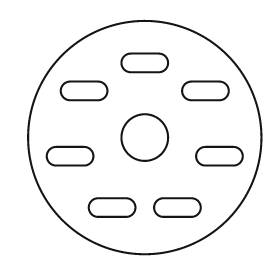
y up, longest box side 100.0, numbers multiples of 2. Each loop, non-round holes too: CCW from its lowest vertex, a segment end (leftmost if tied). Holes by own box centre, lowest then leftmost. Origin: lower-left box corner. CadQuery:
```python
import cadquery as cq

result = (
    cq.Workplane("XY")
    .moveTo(50.0, 50.0)
    .circle(50.0)
    .moveTo(30.0, 16.0)
    .lineTo(42.0, 16.0)
    .threePointArc((46.0, 20.0), (42.0, 24.0))
    .lineTo(30.0, 24.0)
    .threePointArc((26.0, 20.0), (30.0, 16.0))
    .close()
    .moveTo(58.0, 16.0)
    .lineTo(70.0, 16.0)
    .threePointArc((74.0, 20.0), (70.0, 24.0))
    .lineTo(58.0, 24.0)
    .threePointArc((54.0, 20.0), (58.0, 16.0))
    .close()
    .moveTo(12.0, 38.0)
    .lineTo(24.0, 38.0)
    .threePointArc((28.0, 42.0), (24.0, 46.0))
    .lineTo(12.0, 46.0)
    .threePointArc((8.0, 42.0), (12.0, 38.0))
    .close()
    .moveTo(76.0, 38.0)
    .lineTo(88.0, 38.0)
    .threePointArc((92.0, 42.0), (88.0, 46.0))
    .lineTo(76.0, 46.0)
    .threePointArc((72.0, 42.0), (76.0, 38.0))
    .close()
    .moveTo(50.0, 50.0)
    .circle(10.0)
    .moveTo(18.0, 66.0)
    .lineTo(30.0, 66.0)
    .threePointArc((34.0, 70.0), (30.0, 74.0))
    .lineTo(18.0, 74.0)
    .threePointArc((14.0, 70.0), (18.0, 66.0))
    .close()
    .moveTo(70.0, 66.0)
    .lineTo(82.0, 66.0)
    .threePointArc((86.0, 70.0), (82.0, 74.0))
    .lineTo(70.0, 74.0)
    .threePointArc((66.0, 70.0), (70.0, 66.0))
    .close()
    .moveTo(44.0, 78.0)
    .lineTo(56.0, 78.0)
    .threePointArc((60.0, 82.0), (56.0, 86.0))
    .lineTo(44.0, 86.0)
    .threePointArc((40.0, 82.0), (44.0, 78.0))
    .close()
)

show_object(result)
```